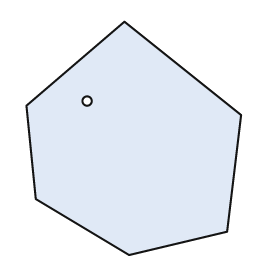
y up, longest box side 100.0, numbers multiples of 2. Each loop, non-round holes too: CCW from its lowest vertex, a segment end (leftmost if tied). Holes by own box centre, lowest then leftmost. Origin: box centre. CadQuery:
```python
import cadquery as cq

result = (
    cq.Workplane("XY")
    .moveTo(-2.0, -50.0)
    .lineTo(40.0, -40.0)
    .lineTo(46.0, 10.0)
    .lineTo(-4.0, 50.0)
    .lineTo(-46.0, 14.0)
    .lineTo(-42.0, -26.0)
    .close()
    .moveTo(-20.0, 16.0)
    .circle(2.0)
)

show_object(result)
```